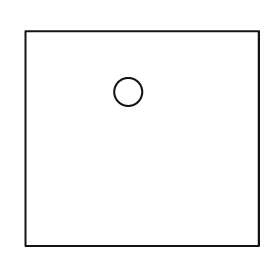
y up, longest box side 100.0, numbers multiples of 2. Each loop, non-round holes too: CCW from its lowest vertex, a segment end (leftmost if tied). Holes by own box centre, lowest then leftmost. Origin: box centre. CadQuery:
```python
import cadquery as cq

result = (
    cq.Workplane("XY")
    .moveTo(-50.0, -46.0)
    .lineTo(50.0, -46.0)
    .lineTo(50.0, 46.0)
    .lineTo(-50.0, 46.0)
    .close()
    .moveTo(-6.0, 20.0)
    .circle(6.0)
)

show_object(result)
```